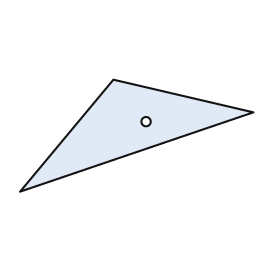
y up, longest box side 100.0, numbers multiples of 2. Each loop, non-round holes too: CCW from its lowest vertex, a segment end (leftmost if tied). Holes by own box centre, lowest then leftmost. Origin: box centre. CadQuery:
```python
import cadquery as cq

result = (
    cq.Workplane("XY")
    .moveTo(-50.0, -24.0)
    .lineTo(50.0, 10.0)
    .lineTo(-10.0, 24.0)
    .close()
    .moveTo(4.0, 6.0)
    .circle(2.0)
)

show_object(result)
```